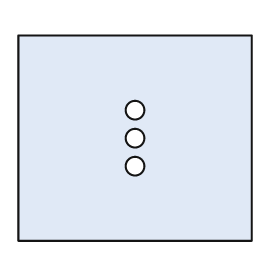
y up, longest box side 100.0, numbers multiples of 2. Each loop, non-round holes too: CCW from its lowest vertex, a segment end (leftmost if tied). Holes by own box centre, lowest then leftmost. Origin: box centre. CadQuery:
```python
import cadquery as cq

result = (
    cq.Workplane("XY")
    .moveTo(-50.0, -44.0)
    .lineTo(50.0, -44.0)
    .lineTo(50.0, 44.0)
    .lineTo(-50.0, 44.0)
    .close()
    .moveTo(0.0, -12.0)
    .circle(4.0)
    .moveTo(0.0, 0.0)
    .circle(4.0)
    .moveTo(0.0, 12.0)
    .circle(4.0)
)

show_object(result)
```